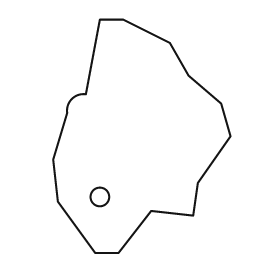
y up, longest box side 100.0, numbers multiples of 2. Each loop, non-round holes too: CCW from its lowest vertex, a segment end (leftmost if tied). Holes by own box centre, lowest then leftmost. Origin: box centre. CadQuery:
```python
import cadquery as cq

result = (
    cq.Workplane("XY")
    .moveTo(-20.0, -50.0)
    .lineTo(-10.0, -50.0)
    .lineTo(4.0, -32.0)
    .lineTo(22.0, -34.0)
    .lineTo(24.0, -20.0)
    .lineTo(38.0, 0.0)
    .lineTo(34.0, 14.0)
    .lineTo(20.0, 26.0)
    .lineTo(12.0, 40.0)
    .lineTo(-8.0, 50.0)
    .lineTo(-18.0, 50.0)
    .lineTo(-24.0, 18.0)
    .threePointArc((-30.0, 16.0), (-32.0, 10.0))
    .lineTo(-38.0, -10.0)
    .lineTo(-36.0, -28.0)
    .close()
    .moveTo(-18.0, -26.0)
    .circle(4.0)
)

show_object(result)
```